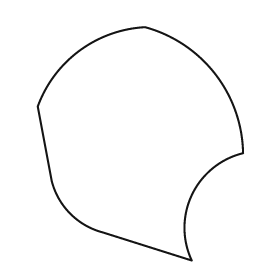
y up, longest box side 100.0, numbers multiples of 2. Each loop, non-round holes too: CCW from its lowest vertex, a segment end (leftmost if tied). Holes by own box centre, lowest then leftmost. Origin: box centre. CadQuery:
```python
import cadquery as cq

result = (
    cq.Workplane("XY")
    .moveTo(22.0, -50.0)
    .threePointArc((22.0, -22.0), (44.0, -4.0))
    .threePointArc((32.0, 30.0), (2.0, 50.0))
    .threePointArc((-26.0, 40.0), (-44.0, 16.0))
    .lineTo(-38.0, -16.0)
    .threePointArc((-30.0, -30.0), (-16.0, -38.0))
    .close()
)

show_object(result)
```